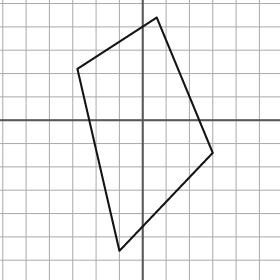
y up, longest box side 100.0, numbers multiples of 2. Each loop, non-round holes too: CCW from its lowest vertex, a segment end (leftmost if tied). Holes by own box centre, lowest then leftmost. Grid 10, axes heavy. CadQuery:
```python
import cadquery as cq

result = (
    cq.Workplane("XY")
    .moveTo(-10.0, -56.0)
    .lineTo(30.0, -14.0)
    .lineTo(6.0, 44.0)
    .lineTo(-28.0, 22.0)
    .close()
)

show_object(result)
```